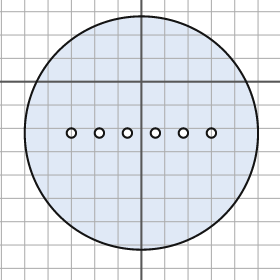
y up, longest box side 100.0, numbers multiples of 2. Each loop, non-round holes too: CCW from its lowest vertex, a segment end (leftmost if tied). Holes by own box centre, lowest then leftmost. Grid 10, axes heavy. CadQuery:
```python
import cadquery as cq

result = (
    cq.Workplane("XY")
    .moveTo(0.0, -22.0)
    .circle(50.0)
    .moveTo(-30.0, -22.0)
    .circle(2.0)
    .moveTo(-18.0, -22.0)
    .circle(2.0)
    .moveTo(-6.0, -22.0)
    .circle(2.0)
    .moveTo(6.0, -22.0)
    .circle(2.0)
    .moveTo(18.0, -22.0)
    .circle(2.0)
    .moveTo(30.0, -22.0)
    .circle(2.0)
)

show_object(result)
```